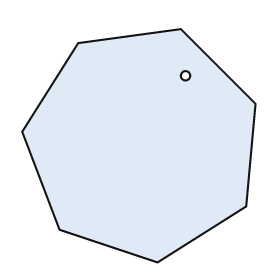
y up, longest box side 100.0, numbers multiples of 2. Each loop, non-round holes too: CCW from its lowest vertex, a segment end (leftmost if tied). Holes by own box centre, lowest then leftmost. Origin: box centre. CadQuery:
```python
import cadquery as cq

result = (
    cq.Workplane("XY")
    .moveTo(8.0, -50.0)
    .lineTo(46.0, -26.0)
    .lineTo(50.0, 18.0)
    .lineTo(18.0, 50.0)
    .lineTo(-26.0, 44.0)
    .lineTo(-50.0, 6.0)
    .lineTo(-34.0, -36.0)
    .close()
    .moveTo(20.0, 30.0)
    .circle(2.0)
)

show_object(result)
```